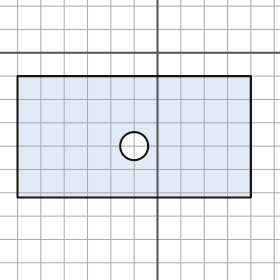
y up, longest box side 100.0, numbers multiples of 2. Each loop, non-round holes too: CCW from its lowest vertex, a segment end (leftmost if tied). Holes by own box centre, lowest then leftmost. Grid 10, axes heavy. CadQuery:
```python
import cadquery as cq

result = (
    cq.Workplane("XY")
    .moveTo(-60.0, -62.0)
    .lineTo(40.0, -62.0)
    .lineTo(40.0, -10.0)
    .lineTo(-60.0, -10.0)
    .close()
    .moveTo(-10.0, -40.0)
    .circle(6.0)
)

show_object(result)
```